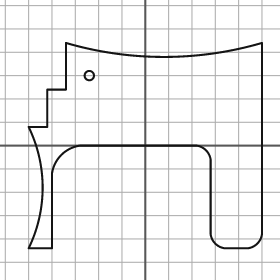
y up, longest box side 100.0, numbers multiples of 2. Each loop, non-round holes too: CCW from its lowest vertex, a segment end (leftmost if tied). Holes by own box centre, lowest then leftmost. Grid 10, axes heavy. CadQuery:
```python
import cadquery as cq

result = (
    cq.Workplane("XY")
    .moveTo(-50.0, -44.0)
    .lineTo(-40.0, -44.0)
    .lineTo(-40.0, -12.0)
    .threePointArc((-36.0, -4.0), (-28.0, 0.0))
    .lineTo(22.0, 0.0)
    .threePointArc((26.0, -2.0), (28.0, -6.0))
    .lineTo(28.0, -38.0)
    .threePointArc((30.0, -42.0), (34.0, -44.0))
    .lineTo(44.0, -44.0)
    .threePointArc((48.0, -42.0), (50.0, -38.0))
    .lineTo(50.0, 44.0)
    .threePointArc((8.0, 38.0), (-34.0, 44.0))
    .lineTo(-34.0, 24.0)
    .lineTo(-42.0, 24.0)
    .lineTo(-42.0, 8.0)
    .lineTo(-50.0, 8.0)
    .threePointArc((-44.0, -18.0), (-50.0, -44.0))
    .close()
    .moveTo(-24.0, 30.0)
    .circle(2.0)
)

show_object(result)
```